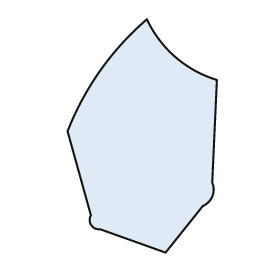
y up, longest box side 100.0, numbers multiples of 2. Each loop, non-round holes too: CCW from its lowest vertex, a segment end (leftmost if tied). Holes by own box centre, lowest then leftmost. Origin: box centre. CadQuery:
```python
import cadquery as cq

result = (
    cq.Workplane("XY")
    .moveTo(10.0, -50.0)
    .lineTo(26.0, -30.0)
    .threePointArc((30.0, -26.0), (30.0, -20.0))
    .lineTo(32.0, 24.0)
    .threePointArc((14.0, 34.0), (2.0, 50.0))
    .threePointArc((-18.0, 28.0), (-32.0, 2.0))
    .lineTo(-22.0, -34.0)
    .threePointArc((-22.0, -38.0), (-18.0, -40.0))
    .close()
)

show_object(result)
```